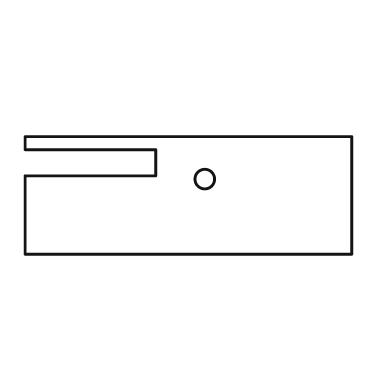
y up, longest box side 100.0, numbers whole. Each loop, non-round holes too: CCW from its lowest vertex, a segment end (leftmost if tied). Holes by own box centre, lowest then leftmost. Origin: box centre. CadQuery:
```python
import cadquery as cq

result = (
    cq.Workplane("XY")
    .moveTo(-50.0, -18.0)
    .lineTo(50.0, -18.0)
    .lineTo(50.0, 18.0)
    .lineTo(-50.0, 18.0)
    .lineTo(-50.0, 14.0)
    .lineTo(-10.0, 14.0)
    .lineTo(-10.0, 6.0)
    .lineTo(-50.0, 6.0)
    .close()
    .moveTo(5.0, 5.0)
    .circle(3.0)
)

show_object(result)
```